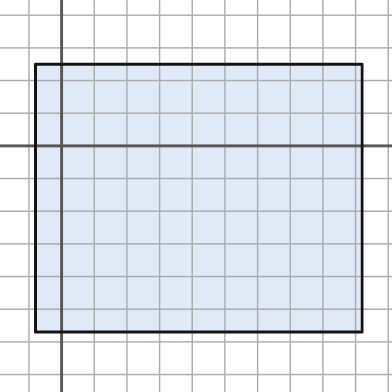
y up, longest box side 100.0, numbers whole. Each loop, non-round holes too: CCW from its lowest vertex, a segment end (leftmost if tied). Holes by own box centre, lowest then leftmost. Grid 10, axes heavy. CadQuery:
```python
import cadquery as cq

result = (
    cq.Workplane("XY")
    .moveTo(-8.0, -57.0)
    .lineTo(92.0, -57.0)
    .lineTo(92.0, 25.0)
    .lineTo(-8.0, 25.0)
    .close()
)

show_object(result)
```